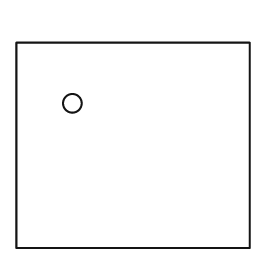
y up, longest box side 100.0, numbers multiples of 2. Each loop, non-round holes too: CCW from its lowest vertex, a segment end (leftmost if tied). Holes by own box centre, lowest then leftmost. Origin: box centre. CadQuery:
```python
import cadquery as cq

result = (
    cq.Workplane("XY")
    .moveTo(-50.0, -44.0)
    .lineTo(50.0, -44.0)
    .lineTo(50.0, 44.0)
    .lineTo(-50.0, 44.0)
    .close()
    .moveTo(-26.0, 18.0)
    .circle(4.0)
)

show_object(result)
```